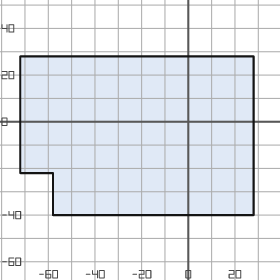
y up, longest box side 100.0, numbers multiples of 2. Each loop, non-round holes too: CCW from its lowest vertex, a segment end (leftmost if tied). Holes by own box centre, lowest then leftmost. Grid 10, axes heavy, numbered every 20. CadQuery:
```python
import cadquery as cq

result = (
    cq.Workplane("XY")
    .moveTo(-58.0, -40.0)
    .lineTo(28.0, -40.0)
    .lineTo(28.0, 28.0)
    .lineTo(-72.0, 28.0)
    .lineTo(-72.0, -22.0)
    .lineTo(-58.0, -22.0)
    .close()
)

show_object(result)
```